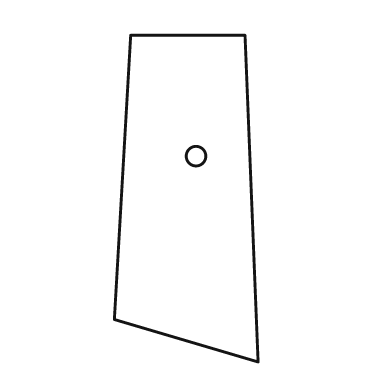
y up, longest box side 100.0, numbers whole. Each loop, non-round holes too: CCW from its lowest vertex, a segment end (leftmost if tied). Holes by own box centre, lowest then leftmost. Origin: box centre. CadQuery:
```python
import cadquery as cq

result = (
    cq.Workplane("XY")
    .moveTo(22.0, -50.0)
    .lineTo(18.0, 50.0)
    .lineTo(-17.0, 50.0)
    .lineTo(-22.0, -37.0)
    .close()
    .moveTo(3.0, 13.0)
    .circle(3.0)
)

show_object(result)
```